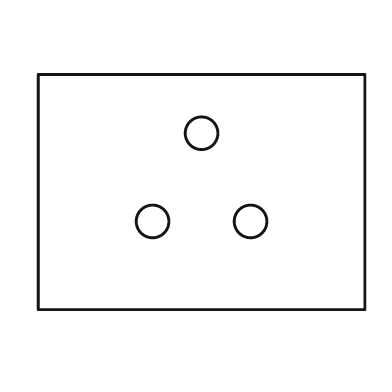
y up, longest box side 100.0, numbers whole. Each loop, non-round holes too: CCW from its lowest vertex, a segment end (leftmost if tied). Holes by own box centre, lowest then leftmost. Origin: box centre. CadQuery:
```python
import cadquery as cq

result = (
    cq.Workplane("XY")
    .moveTo(-50.0, -36.0)
    .lineTo(50.0, -36.0)
    .lineTo(50.0, 36.0)
    .lineTo(-50.0, 36.0)
    .close()
    .moveTo(-15.0, -9.0)
    .circle(5.0)
    .moveTo(15.0, -9.0)
    .circle(5.0)
    .moveTo(0.0, 18.0)
    .circle(5.0)
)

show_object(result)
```